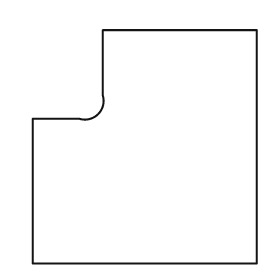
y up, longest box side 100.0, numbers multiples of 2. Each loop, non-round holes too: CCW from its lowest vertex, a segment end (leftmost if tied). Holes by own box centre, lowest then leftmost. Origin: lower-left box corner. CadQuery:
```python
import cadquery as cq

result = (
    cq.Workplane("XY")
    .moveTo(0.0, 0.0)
    .lineTo(96.0, 0.0)
    .lineTo(96.0, 100.0)
    .lineTo(30.0, 100.0)
    .lineTo(30.0, 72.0)
    .threePointArc((28.0, 64.0), (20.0, 62.0))
    .lineTo(0.0, 62.0)
    .close()
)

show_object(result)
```